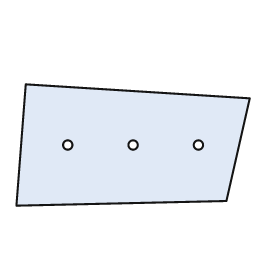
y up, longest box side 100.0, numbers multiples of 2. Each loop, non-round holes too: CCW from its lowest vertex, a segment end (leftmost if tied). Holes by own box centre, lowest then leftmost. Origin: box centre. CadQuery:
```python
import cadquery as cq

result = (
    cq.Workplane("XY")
    .moveTo(-50.0, -26.0)
    .lineTo(40.0, -24.0)
    .lineTo(50.0, 20.0)
    .lineTo(-46.0, 26.0)
    .close()
    .moveTo(-28.0, 0.0)
    .circle(2.0)
    .moveTo(0.0, 0.0)
    .circle(2.0)
    .moveTo(28.0, 0.0)
    .circle(2.0)
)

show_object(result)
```